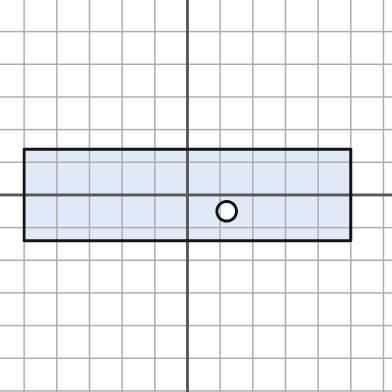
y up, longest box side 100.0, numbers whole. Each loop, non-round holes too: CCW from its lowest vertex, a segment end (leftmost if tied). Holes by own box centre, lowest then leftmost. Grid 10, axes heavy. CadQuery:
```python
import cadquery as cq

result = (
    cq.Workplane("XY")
    .moveTo(-50.0, -14.0)
    .lineTo(50.0, -14.0)
    .lineTo(50.0, 14.0)
    .lineTo(-50.0, 14.0)
    .close()
    .moveTo(12.0, -5.0)
    .circle(3.0)
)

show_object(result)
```